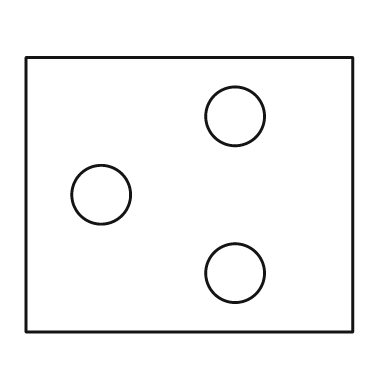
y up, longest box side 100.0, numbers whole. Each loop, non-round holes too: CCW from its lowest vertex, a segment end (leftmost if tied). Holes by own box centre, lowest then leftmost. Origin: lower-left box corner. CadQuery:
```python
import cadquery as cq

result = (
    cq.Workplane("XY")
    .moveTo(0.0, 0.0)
    .lineTo(100.0, 0.0)
    .lineTo(100.0, 84.0)
    .lineTo(0.0, 84.0)
    .close()
    .moveTo(64.0, 18.0)
    .circle(9.0)
    .moveTo(23.0, 42.0)
    .circle(9.0)
    .moveTo(64.0, 66.0)
    .circle(9.0)
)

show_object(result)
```